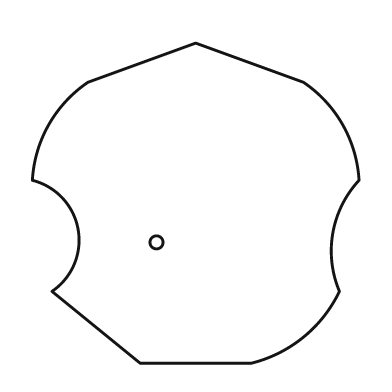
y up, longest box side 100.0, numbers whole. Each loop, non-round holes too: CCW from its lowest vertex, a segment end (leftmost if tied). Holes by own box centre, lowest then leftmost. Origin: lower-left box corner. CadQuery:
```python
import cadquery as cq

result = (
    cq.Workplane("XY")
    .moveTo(33.0, 0.0)
    .lineTo(67.0, 0.0)
    .threePointArc((83.0, 8.0), (94.0, 22.0))
    .threePointArc((92.0, 40.0), (100.0, 56.0))
    .threePointArc((95.0, 73.0), (83.0, 86.0))
    .lineTo(50.0, 98.0)
    .lineTo(17.0, 86.0)
    .threePointArc((5.0, 73.0), (0.0, 56.0))
    .threePointArc((14.0, 41.0), (6.0, 22.0))
    .close()
    .moveTo(38.0, 37.0)
    .circle(2.0)
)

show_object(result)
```